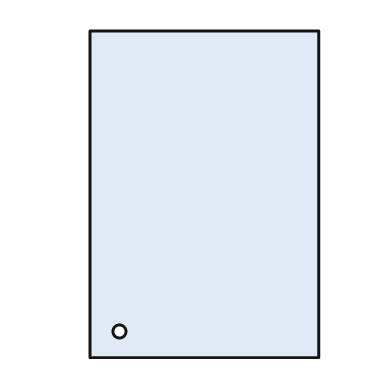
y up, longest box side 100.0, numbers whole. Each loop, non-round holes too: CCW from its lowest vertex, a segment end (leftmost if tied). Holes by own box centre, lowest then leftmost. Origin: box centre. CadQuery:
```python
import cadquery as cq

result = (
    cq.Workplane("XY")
    .moveTo(-35.0, -50.0)
    .lineTo(35.0, -50.0)
    .lineTo(35.0, 50.0)
    .lineTo(-35.0, 50.0)
    .close()
    .moveTo(-26.0, -42.0)
    .circle(2.0)
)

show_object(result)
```